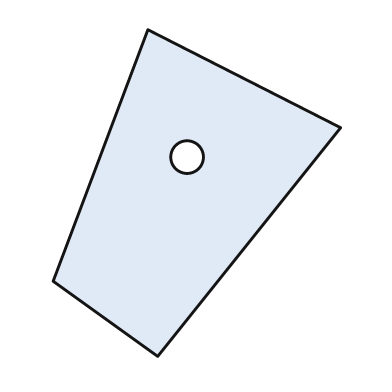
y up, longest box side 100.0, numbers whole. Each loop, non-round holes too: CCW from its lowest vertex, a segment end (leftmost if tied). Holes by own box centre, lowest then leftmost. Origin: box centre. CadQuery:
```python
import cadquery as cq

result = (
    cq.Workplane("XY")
    .moveTo(-12.0, -50.0)
    .lineTo(44.0, 20.0)
    .lineTo(-15.0, 50.0)
    .lineTo(-44.0, -27.0)
    .close()
    .moveTo(-3.0, 11.0)
    .circle(5.0)
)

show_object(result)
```